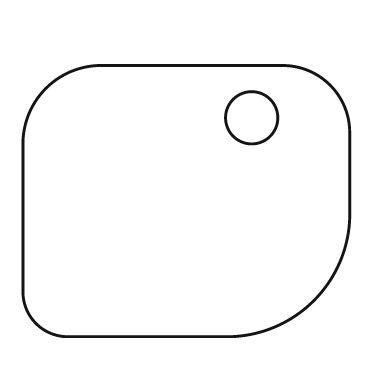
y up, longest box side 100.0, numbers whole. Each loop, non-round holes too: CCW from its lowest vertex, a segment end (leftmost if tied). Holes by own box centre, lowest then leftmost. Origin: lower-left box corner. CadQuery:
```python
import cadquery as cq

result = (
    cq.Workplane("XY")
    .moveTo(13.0, 0.0)
    .lineTo(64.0, 0.0)
    .threePointArc((89.0, 11.0), (100.0, 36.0))
    .lineTo(100.0, 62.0)
    .threePointArc((94.0, 77.0), (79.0, 83.0))
    .lineTo(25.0, 83.0)
    .threePointArc((7.0, 76.0), (0.0, 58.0))
    .lineTo(0.0, 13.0)
    .threePointArc((4.0, 4.0), (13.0, 0.0))
    .close()
    .moveTo(70.0, 67.0)
    .circle(8.0)
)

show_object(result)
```